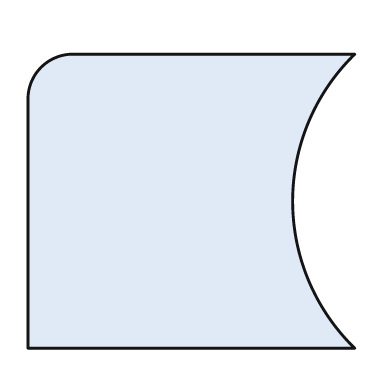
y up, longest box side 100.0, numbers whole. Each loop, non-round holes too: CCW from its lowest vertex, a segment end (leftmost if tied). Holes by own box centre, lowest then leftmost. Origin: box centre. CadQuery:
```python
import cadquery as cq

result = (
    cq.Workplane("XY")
    .moveTo(-50.0, -45.0)
    .lineTo(50.0, -45.0)
    .threePointArc((31.0, 0.0), (50.0, 45.0))
    .lineTo(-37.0, 45.0)
    .threePointArc((-46.0, 41.0), (-50.0, 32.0))
    .close()
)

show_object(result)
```